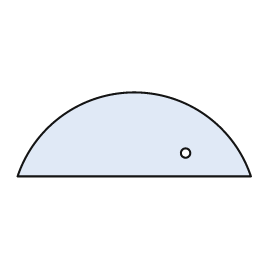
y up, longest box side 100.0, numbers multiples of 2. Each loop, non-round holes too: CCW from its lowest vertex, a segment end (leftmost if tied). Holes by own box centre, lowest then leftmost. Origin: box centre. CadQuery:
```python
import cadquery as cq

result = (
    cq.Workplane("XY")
    .moveTo(-50.0, -18.0)
    .lineTo(50.0, -18.0)
    .threePointArc((0.0, 18.0), (-50.0, -18.0))
    .close()
    .moveTo(22.0, -8.0)
    .circle(2.0)
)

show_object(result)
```